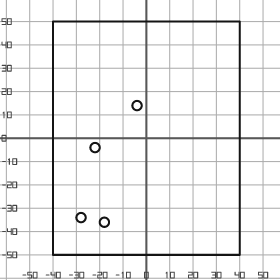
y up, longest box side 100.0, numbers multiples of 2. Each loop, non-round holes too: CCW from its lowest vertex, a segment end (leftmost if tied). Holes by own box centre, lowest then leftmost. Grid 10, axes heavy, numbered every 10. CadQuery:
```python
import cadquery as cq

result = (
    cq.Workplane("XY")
    .moveTo(-40.0, -50.0)
    .lineTo(40.0, -50.0)
    .lineTo(40.0, 50.0)
    .lineTo(-40.0, 50.0)
    .close()
    .moveTo(-18.0, -36.0)
    .circle(2.0)
    .moveTo(-28.0, -34.0)
    .circle(2.0)
    .moveTo(-22.0, -4.0)
    .circle(2.0)
    .moveTo(-4.0, 14.0)
    .circle(2.0)
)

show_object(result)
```